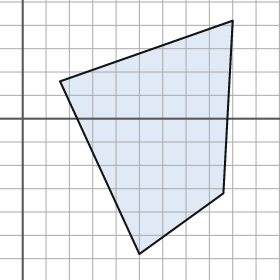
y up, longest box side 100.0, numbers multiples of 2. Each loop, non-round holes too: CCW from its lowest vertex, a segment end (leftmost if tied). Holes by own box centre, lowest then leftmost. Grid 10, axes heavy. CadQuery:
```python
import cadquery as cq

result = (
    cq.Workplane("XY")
    .moveTo(50.0, -58.0)
    .lineTo(86.0, -32.0)
    .lineTo(90.0, 42.0)
    .lineTo(16.0, 16.0)
    .close()
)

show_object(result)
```